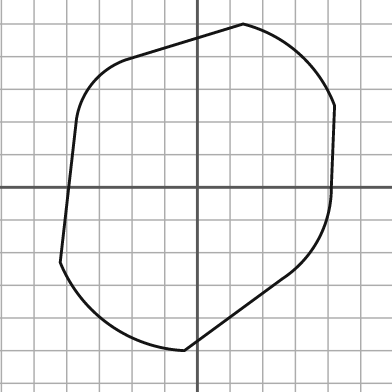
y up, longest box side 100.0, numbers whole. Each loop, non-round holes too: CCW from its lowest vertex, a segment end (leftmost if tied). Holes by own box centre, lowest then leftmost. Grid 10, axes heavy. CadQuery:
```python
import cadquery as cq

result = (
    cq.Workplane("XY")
    .moveTo(-4.0, -50.0)
    .lineTo(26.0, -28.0)
    .threePointArc((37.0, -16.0), (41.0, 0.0))
    .lineTo(42.0, 25.0)
    .threePointArc((31.0, 41.0), (14.0, 50.0))
    .lineTo(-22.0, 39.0)
    .threePointArc((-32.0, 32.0), (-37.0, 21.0))
    .lineTo(-42.0, -23.0)
    .threePointArc((-27.0, -42.0), (-4.0, -50.0))
    .close()
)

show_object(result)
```